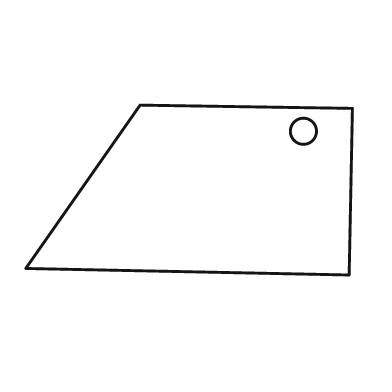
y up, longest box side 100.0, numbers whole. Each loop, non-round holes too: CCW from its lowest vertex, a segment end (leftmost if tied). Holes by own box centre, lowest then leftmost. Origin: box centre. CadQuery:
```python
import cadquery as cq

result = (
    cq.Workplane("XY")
    .moveTo(49.0, -26.0)
    .lineTo(50.0, 25.0)
    .lineTo(-15.0, 26.0)
    .lineTo(-50.0, -24.0)
    .close()
    .moveTo(35.0, 18.0)
    .circle(4.0)
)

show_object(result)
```